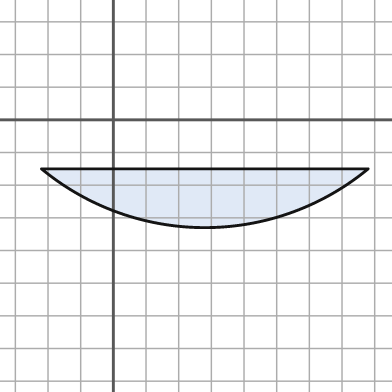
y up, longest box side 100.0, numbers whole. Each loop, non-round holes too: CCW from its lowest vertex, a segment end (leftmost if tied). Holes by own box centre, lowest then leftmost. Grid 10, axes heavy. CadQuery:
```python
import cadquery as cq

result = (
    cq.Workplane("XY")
    .moveTo(-22.0, -15.0)
    .threePointArc((28.0, -33.0), (78.0, -15.0))
    .close()
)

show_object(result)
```